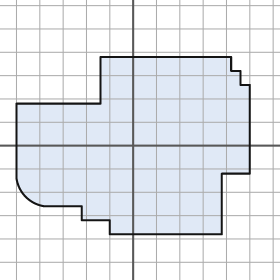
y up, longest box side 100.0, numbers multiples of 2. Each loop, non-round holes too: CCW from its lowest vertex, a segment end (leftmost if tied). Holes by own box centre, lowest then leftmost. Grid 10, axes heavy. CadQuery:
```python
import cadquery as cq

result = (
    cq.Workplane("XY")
    .moveTo(-10.0, -38.0)
    .lineTo(38.0, -38.0)
    .lineTo(38.0, -12.0)
    .lineTo(50.0, -12.0)
    .lineTo(50.0, 26.0)
    .lineTo(46.0, 26.0)
    .lineTo(46.0, 32.0)
    .lineTo(42.0, 32.0)
    .lineTo(42.0, 38.0)
    .lineTo(-14.0, 38.0)
    .lineTo(-14.0, 18.0)
    .lineTo(-50.0, 18.0)
    .lineTo(-50.0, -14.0)
    .threePointArc((-46.0, -22.0), (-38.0, -26.0))
    .lineTo(-22.0, -26.0)
    .lineTo(-22.0, -32.0)
    .lineTo(-10.0, -32.0)
    .close()
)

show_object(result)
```